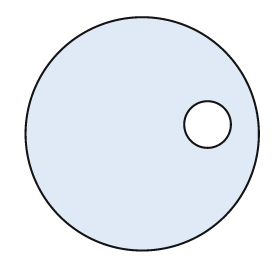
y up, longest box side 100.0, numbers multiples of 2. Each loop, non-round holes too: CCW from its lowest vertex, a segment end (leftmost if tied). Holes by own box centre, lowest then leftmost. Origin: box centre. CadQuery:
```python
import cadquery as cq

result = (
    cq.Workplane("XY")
    .moveTo(0.0, 0.0)
    .circle(50.0)
    .moveTo(28.0, 4.0)
    .circle(10.0)
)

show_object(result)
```